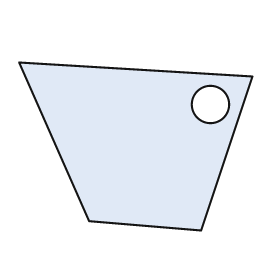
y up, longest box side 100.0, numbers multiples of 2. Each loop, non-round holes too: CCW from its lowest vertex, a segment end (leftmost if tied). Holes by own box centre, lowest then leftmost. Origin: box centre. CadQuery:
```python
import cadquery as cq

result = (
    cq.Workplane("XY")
    .moveTo(28.0, -36.0)
    .lineTo(50.0, 30.0)
    .lineTo(-50.0, 36.0)
    .lineTo(-20.0, -32.0)
    .close()
    .moveTo(32.0, 18.0)
    .circle(8.0)
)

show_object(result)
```